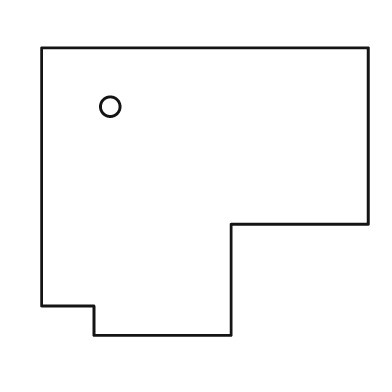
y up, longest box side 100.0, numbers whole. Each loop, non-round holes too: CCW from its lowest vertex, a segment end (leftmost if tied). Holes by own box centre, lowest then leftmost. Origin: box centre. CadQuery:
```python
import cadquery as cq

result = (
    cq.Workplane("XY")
    .moveTo(-34.0, -44.0)
    .lineTo(8.0, -44.0)
    .lineTo(8.0, -10.0)
    .lineTo(50.0, -10.0)
    .lineTo(50.0, 44.0)
    .lineTo(-50.0, 44.0)
    .lineTo(-50.0, -35.0)
    .lineTo(-34.0, -35.0)
    .close()
    .moveTo(-29.0, 26.0)
    .circle(3.0)
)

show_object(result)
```